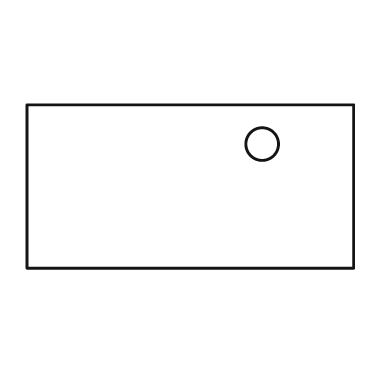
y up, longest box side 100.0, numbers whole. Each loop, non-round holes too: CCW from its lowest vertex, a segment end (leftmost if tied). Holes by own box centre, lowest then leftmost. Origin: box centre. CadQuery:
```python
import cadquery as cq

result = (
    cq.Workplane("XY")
    .moveTo(-50.0, -25.0)
    .lineTo(50.0, -25.0)
    .lineTo(50.0, 25.0)
    .lineTo(-50.0, 25.0)
    .close()
    .moveTo(22.0, 13.0)
    .circle(5.0)
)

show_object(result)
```